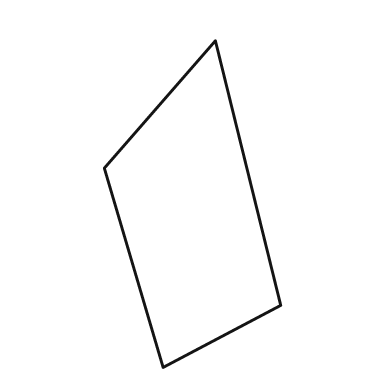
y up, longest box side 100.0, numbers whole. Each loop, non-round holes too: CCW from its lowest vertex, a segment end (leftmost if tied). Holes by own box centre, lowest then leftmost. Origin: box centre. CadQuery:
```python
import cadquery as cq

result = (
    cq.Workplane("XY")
    .moveTo(-9.0, -50.0)
    .lineTo(27.0, -31.0)
    .lineTo(7.0, 50.0)
    .lineTo(-27.0, 11.0)
    .close()
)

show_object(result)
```